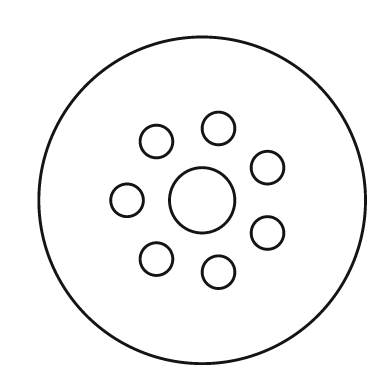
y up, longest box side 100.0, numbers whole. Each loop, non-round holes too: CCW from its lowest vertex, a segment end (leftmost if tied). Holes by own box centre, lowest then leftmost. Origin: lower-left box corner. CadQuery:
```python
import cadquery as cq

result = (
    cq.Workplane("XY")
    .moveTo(50.0, 50.0)
    .circle(50.0)
    .moveTo(55.0, 28.0)
    .circle(5.0)
    .moveTo(36.0, 32.0)
    .circle(5.0)
    .moveTo(70.0, 40.0)
    .circle(5.0)
    .moveTo(27.0, 50.0)
    .circle(5.0)
    .moveTo(50.0, 50.0)
    .circle(10.0)
    .moveTo(70.0, 60.0)
    .circle(5.0)
    .moveTo(36.0, 68.0)
    .circle(5.0)
    .moveTo(55.0, 72.0)
    .circle(5.0)
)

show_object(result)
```